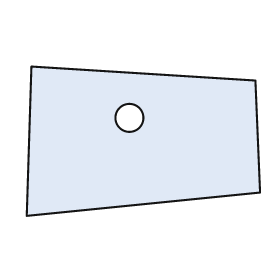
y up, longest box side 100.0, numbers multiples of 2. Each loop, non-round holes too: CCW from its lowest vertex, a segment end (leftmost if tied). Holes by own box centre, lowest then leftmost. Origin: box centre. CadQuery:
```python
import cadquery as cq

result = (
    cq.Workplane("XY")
    .moveTo(-50.0, -32.0)
    .lineTo(50.0, -22.0)
    .lineTo(48.0, 26.0)
    .lineTo(-48.0, 32.0)
    .close()
    .moveTo(-6.0, 10.0)
    .circle(6.0)
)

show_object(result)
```